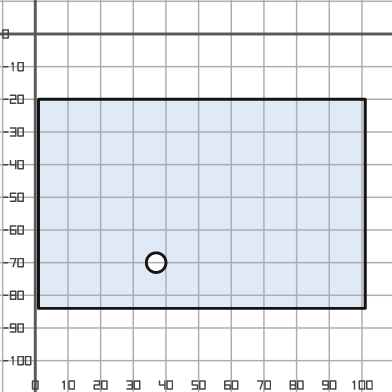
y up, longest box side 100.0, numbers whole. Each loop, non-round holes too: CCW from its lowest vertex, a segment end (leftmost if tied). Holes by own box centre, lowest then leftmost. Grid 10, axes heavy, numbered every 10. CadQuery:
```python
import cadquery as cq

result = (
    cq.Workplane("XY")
    .moveTo(1.0, -84.0)
    .lineTo(101.0, -84.0)
    .lineTo(101.0, -20.0)
    .lineTo(1.0, -20.0)
    .close()
    .moveTo(37.0, -70.0)
    .circle(3.0)
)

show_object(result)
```